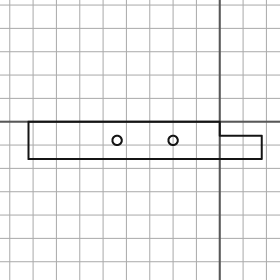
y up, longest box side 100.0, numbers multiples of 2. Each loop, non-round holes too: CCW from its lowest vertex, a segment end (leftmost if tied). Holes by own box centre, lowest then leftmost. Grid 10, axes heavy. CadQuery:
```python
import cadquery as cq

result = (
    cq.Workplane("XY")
    .moveTo(-82.0, -16.0)
    .lineTo(18.0, -16.0)
    .lineTo(18.0, -6.0)
    .lineTo(0.0, -6.0)
    .lineTo(0.0, 0.0)
    .lineTo(-82.0, 0.0)
    .close()
    .moveTo(-44.0, -8.0)
    .circle(2.0)
    .moveTo(-20.0, -8.0)
    .circle(2.0)
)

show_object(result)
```